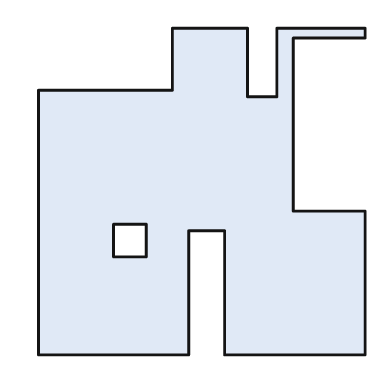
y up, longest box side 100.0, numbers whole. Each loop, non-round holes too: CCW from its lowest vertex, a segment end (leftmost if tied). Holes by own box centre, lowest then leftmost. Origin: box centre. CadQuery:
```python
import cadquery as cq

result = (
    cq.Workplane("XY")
    .moveTo(-50.0, -50.0)
    .lineTo(-4.0, -50.0)
    .lineTo(-4.0, -12.0)
    .lineTo(7.0, -12.0)
    .lineTo(7.0, -50.0)
    .lineTo(50.0, -50.0)
    .lineTo(50.0, -6.0)
    .lineTo(28.0, -6.0)
    .lineTo(28.0, 47.0)
    .lineTo(50.0, 47.0)
    .lineTo(50.0, 50.0)
    .lineTo(23.0, 50.0)
    .lineTo(23.0, 29.0)
    .lineTo(14.0, 29.0)
    .lineTo(14.0, 50.0)
    .lineTo(-9.0, 50.0)
    .lineTo(-9.0, 31.0)
    .lineTo(-50.0, 31.0)
    .close()
    .moveTo(-27.0, -20.0)
    .lineTo(-17.0, -20.0)
    .lineTo(-17.0, -10.0)
    .lineTo(-27.0, -10.0)
    .close()
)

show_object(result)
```